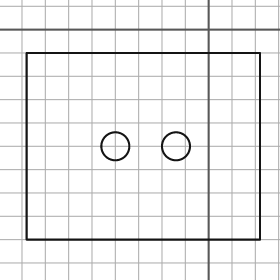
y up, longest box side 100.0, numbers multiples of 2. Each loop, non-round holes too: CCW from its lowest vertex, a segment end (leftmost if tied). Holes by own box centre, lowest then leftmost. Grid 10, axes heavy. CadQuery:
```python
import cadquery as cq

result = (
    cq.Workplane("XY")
    .moveTo(-78.0, -90.0)
    .lineTo(22.0, -90.0)
    .lineTo(22.0, -10.0)
    .lineTo(-78.0, -10.0)
    .close()
    .moveTo(-40.0, -50.0)
    .circle(6.0)
    .moveTo(-14.0, -50.0)
    .circle(6.0)
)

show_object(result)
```